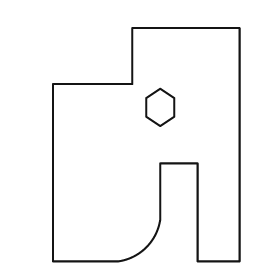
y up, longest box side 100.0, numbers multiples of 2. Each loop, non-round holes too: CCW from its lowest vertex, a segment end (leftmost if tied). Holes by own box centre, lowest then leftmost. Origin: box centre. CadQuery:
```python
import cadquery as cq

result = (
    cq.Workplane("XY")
    .moveTo(-40.0, -50.0)
    .lineTo(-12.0, -50.0)
    .threePointArc((0.0, -44.0), (6.0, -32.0))
    .lineTo(6.0, -8.0)
    .lineTo(22.0, -8.0)
    .lineTo(22.0, -50.0)
    .lineTo(40.0, -50.0)
    .lineTo(40.0, 50.0)
    .lineTo(-6.0, 50.0)
    .lineTo(-6.0, 26.0)
    .lineTo(-40.0, 26.0)
    .close()
    .moveTo(6.0, 8.0)
    .lineTo(12.0, 12.0)
    .lineTo(12.0, 20.0)
    .lineTo(6.0, 24.0)
    .lineTo(0.0, 20.0)
    .lineTo(0.0, 12.0)
    .close()
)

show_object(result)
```